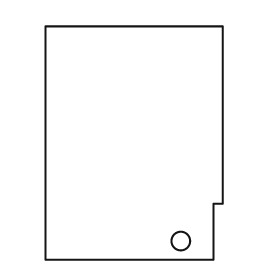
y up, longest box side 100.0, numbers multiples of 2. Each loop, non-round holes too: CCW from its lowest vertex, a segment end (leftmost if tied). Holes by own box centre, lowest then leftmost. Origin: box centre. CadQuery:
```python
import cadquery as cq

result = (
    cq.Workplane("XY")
    .moveTo(-38.0, -50.0)
    .lineTo(34.0, -50.0)
    .lineTo(34.0, -26.0)
    .lineTo(38.0, -26.0)
    .lineTo(38.0, 50.0)
    .lineTo(-38.0, 50.0)
    .close()
    .moveTo(20.0, -42.0)
    .circle(4.0)
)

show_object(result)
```